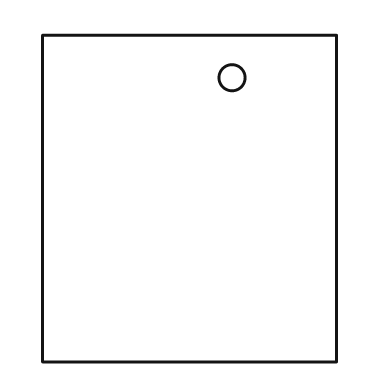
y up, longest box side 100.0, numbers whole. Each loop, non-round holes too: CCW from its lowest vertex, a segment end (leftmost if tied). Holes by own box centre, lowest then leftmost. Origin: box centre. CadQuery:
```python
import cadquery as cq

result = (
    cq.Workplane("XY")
    .moveTo(-45.0, -50.0)
    .lineTo(45.0, -50.0)
    .lineTo(45.0, 50.0)
    .lineTo(-45.0, 50.0)
    .close()
    .moveTo(13.0, 37.0)
    .circle(4.0)
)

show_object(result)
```